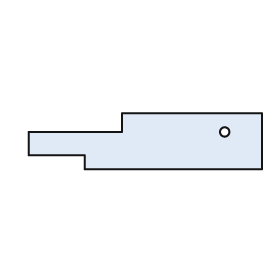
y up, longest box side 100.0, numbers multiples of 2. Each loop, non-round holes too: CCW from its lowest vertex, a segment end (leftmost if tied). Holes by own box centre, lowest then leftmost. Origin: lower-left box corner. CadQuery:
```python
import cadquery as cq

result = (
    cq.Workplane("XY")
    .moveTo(24.0, 0.0)
    .lineTo(100.0, 0.0)
    .lineTo(100.0, 24.0)
    .lineTo(40.0, 24.0)
    .lineTo(40.0, 16.0)
    .lineTo(0.0, 16.0)
    .lineTo(0.0, 6.0)
    .lineTo(24.0, 6.0)
    .close()
    .moveTo(84.0, 16.0)
    .circle(2.0)
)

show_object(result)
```